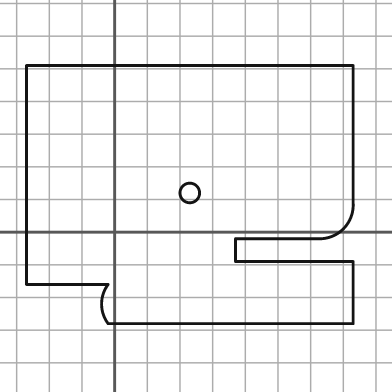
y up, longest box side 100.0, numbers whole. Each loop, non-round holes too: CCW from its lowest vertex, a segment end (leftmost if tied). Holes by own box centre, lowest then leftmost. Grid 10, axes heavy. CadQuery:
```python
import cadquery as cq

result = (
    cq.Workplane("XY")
    .moveTo(-2.0, -28.0)
    .lineTo(73.0, -28.0)
    .lineTo(73.0, -9.0)
    .lineTo(37.0, -9.0)
    .lineTo(37.0, -2.0)
    .lineTo(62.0, -2.0)
    .threePointArc((70.0, 1.0), (73.0, 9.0))
    .lineTo(73.0, 51.0)
    .lineTo(-27.0, 51.0)
    .lineTo(-27.0, -16.0)
    .lineTo(-2.0, -16.0)
    .threePointArc((-4.0, -22.0), (-2.0, -28.0))
    .close()
    .moveTo(23.0, 12.0)
    .circle(3.0)
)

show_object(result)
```